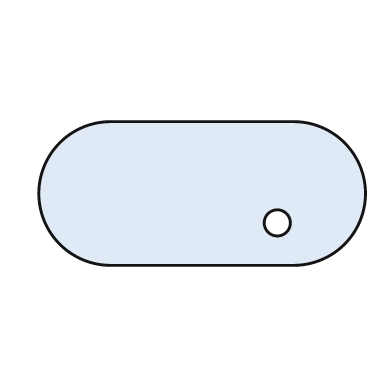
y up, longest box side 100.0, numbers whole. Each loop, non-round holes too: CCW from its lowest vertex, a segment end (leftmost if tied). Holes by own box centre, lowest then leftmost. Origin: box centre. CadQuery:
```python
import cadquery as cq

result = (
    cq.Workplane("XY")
    .moveTo(-28.0, -22.0)
    .lineTo(28.0, -22.0)
    .threePointArc((50.0, 0.0), (28.0, 22.0))
    .lineTo(-28.0, 22.0)
    .threePointArc((-50.0, 0.0), (-28.0, -22.0))
    .close()
    .moveTo(23.0, -9.0)
    .circle(4.0)
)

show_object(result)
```